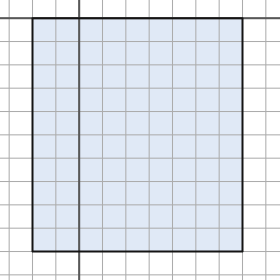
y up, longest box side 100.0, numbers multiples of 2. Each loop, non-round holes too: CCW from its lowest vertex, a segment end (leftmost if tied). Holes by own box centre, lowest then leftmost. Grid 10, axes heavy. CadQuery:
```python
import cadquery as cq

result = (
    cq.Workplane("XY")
    .moveTo(-20.0, -100.0)
    .lineTo(70.0, -100.0)
    .lineTo(70.0, 0.0)
    .lineTo(-20.0, 0.0)
    .close()
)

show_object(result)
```